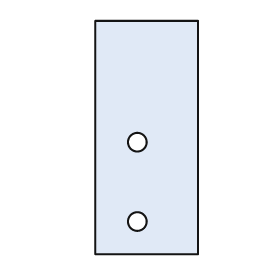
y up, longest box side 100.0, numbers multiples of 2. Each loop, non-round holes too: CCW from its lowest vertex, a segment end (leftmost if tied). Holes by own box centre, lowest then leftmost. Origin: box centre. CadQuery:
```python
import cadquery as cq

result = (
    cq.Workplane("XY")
    .moveTo(-22.0, -50.0)
    .lineTo(22.0, -50.0)
    .lineTo(22.0, 50.0)
    .lineTo(-22.0, 50.0)
    .close()
    .moveTo(-4.0, -36.0)
    .circle(4.0)
    .moveTo(-4.0, -2.0)
    .circle(4.0)
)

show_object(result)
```